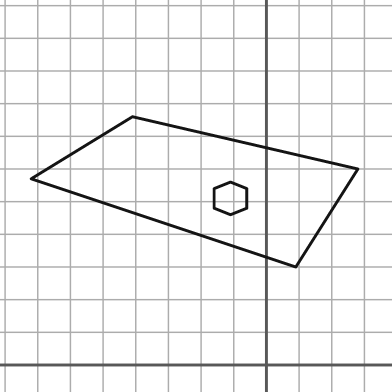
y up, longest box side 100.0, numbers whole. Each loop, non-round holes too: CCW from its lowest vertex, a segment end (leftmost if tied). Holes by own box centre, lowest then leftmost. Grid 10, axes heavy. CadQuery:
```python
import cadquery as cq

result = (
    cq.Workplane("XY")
    .moveTo(9.0, 30.0)
    .lineTo(28.0, 60.0)
    .lineTo(-41.0, 76.0)
    .lineTo(-72.0, 57.0)
    .close()
    .moveTo(-11.0, 46.0)
    .lineTo(-6.0, 48.0)
    .lineTo(-6.0, 54.0)
    .lineTo(-11.0, 56.0)
    .lineTo(-16.0, 54.0)
    .lineTo(-16.0, 48.0)
    .close()
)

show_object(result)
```